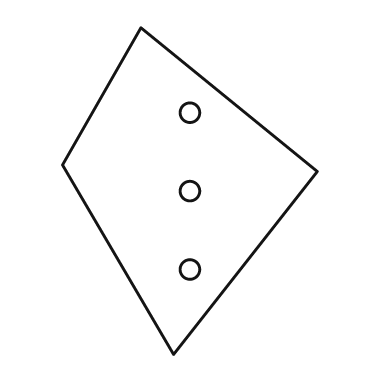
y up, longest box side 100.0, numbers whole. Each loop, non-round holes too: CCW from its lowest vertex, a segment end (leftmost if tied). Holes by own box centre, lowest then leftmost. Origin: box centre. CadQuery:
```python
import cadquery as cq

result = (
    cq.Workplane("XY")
    .moveTo(-5.0, -50.0)
    .lineTo(39.0, 6.0)
    .lineTo(-15.0, 50.0)
    .lineTo(-39.0, 8.0)
    .close()
    .moveTo(0.0, -24.0)
    .circle(3.0)
    .moveTo(0.0, 0.0)
    .circle(3.0)
    .moveTo(0.0, 24.0)
    .circle(3.0)
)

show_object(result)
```